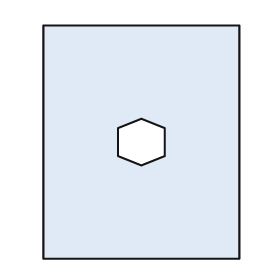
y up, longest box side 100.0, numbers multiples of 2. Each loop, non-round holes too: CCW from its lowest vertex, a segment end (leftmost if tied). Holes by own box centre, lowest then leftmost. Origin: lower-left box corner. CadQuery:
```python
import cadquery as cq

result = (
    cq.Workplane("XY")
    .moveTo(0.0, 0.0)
    .lineTo(84.0, 0.0)
    .lineTo(84.0, 100.0)
    .lineTo(0.0, 100.0)
    .close()
    .moveTo(42.0, 40.0)
    .lineTo(52.0, 44.0)
    .lineTo(52.0, 56.0)
    .lineTo(42.0, 60.0)
    .lineTo(32.0, 56.0)
    .lineTo(32.0, 44.0)
    .close()
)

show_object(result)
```